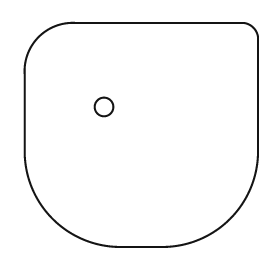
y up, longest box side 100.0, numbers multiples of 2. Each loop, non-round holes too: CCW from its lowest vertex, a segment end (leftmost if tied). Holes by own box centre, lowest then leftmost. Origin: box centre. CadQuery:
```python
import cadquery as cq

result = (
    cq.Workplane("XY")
    .moveTo(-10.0, -48.0)
    .lineTo(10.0, -48.0)
    .threePointArc((38.0, -36.0), (50.0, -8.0))
    .lineTo(50.0, 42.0)
    .threePointArc((48.0, 46.0), (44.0, 48.0))
    .lineTo(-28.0, 48.0)
    .threePointArc((-44.0, 42.0), (-50.0, 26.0))
    .lineTo(-50.0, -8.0)
    .threePointArc((-38.0, -36.0), (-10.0, -48.0))
    .close()
    .moveTo(-16.0, 12.0)
    .circle(4.0)
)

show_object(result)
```